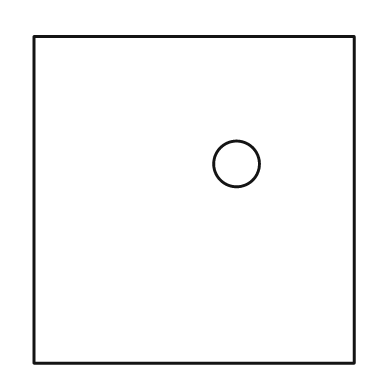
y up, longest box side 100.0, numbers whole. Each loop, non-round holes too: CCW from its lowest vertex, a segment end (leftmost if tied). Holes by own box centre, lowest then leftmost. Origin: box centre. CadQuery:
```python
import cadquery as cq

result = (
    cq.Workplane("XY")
    .moveTo(-49.0, -50.0)
    .lineTo(49.0, -50.0)
    .lineTo(49.0, 50.0)
    .lineTo(-49.0, 50.0)
    .close()
    .moveTo(13.0, 11.0)
    .circle(7.0)
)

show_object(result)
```